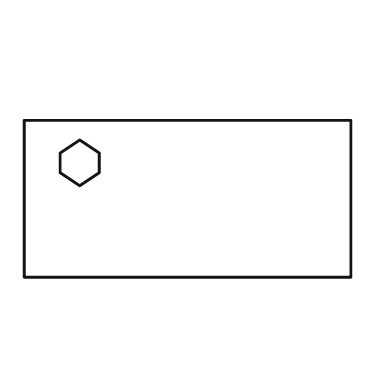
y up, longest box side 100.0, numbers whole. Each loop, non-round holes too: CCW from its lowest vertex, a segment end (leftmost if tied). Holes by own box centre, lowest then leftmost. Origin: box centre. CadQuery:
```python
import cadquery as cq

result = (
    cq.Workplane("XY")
    .moveTo(-50.0, -24.0)
    .lineTo(50.0, -24.0)
    .lineTo(50.0, 24.0)
    .lineTo(-50.0, 24.0)
    .close()
    .moveTo(-33.0, 4.0)
    .lineTo(-27.0, 8.0)
    .lineTo(-27.0, 14.0)
    .lineTo(-33.0, 18.0)
    .lineTo(-39.0, 14.0)
    .lineTo(-39.0, 8.0)
    .close()
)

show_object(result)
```